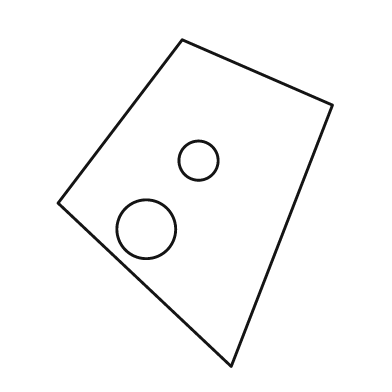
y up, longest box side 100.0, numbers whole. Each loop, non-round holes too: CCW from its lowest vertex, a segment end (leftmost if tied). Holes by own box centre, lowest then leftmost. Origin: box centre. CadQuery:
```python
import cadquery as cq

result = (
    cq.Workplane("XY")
    .moveTo(11.0, -50.0)
    .lineTo(42.0, 30.0)
    .lineTo(-4.0, 50.0)
    .lineTo(-42.0, 0.0)
    .close()
    .moveTo(-15.0, -8.0)
    .circle(9.0)
    .moveTo(1.0, 13.0)
    .circle(6.0)
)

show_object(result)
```